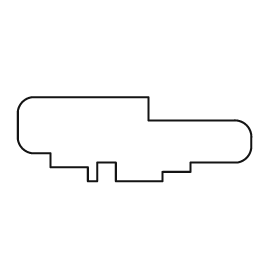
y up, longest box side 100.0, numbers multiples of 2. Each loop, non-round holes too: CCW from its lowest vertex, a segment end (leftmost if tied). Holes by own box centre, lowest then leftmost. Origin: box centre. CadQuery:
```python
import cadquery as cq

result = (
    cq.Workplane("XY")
    .moveTo(-20.0, -18.0)
    .lineTo(-16.0, -18.0)
    .lineTo(-16.0, -10.0)
    .lineTo(-8.0, -10.0)
    .lineTo(-8.0, -18.0)
    .lineTo(12.0, -18.0)
    .lineTo(12.0, -14.0)
    .lineTo(24.0, -14.0)
    .lineTo(24.0, -10.0)
    .lineTo(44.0, -10.0)
    .threePointArc((48.0, -8.0), (50.0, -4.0))
    .lineTo(50.0, 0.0)
    .threePointArc((48.0, 6.0), (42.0, 8.0))
    .lineTo(6.0, 8.0)
    .lineTo(6.0, 18.0)
    .lineTo(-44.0, 18.0)
    .threePointArc((-48.0, 16.0), (-50.0, 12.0))
    .lineTo(-50.0, 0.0)
    .threePointArc((-48.0, -4.0), (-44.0, -6.0))
    .lineTo(-36.0, -6.0)
    .lineTo(-36.0, -12.0)
    .lineTo(-20.0, -12.0)
    .close()
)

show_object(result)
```